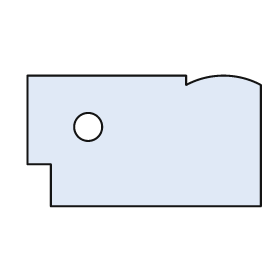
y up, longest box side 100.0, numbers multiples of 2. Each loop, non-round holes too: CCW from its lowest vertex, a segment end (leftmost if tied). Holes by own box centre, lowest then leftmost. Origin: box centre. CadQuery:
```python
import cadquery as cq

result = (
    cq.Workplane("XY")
    .moveTo(-40.0, -28.0)
    .lineTo(50.0, -28.0)
    .lineTo(50.0, 24.0)
    .threePointArc((34.0, 28.0), (18.0, 24.0))
    .lineTo(18.0, 28.0)
    .lineTo(-50.0, 28.0)
    .lineTo(-50.0, -10.0)
    .lineTo(-40.0, -10.0)
    .close()
    .moveTo(-24.0, 6.0)
    .circle(6.0)
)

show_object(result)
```